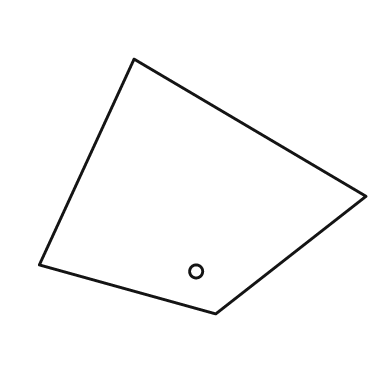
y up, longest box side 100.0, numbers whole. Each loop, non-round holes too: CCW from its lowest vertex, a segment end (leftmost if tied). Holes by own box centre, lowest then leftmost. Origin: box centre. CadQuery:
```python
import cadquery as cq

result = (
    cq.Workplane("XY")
    .moveTo(4.0, -39.0)
    .lineTo(50.0, -3.0)
    .lineTo(-21.0, 39.0)
    .lineTo(-50.0, -24.0)
    .close()
    .moveTo(-2.0, -26.0)
    .circle(2.0)
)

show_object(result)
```